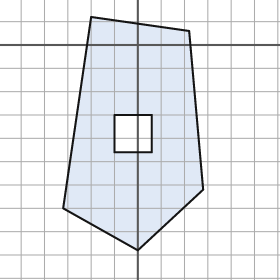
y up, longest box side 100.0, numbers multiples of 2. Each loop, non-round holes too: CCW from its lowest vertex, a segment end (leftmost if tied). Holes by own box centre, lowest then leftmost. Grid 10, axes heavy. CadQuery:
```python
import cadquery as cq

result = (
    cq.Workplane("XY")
    .moveTo(0.0, -88.0)
    .lineTo(28.0, -62.0)
    .lineTo(22.0, 6.0)
    .lineTo(-20.0, 12.0)
    .lineTo(-32.0, -70.0)
    .close()
    .moveTo(-10.0, -46.0)
    .lineTo(6.0, -46.0)
    .lineTo(6.0, -30.0)
    .lineTo(-10.0, -30.0)
    .close()
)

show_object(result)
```